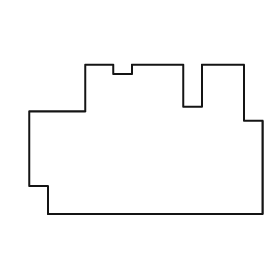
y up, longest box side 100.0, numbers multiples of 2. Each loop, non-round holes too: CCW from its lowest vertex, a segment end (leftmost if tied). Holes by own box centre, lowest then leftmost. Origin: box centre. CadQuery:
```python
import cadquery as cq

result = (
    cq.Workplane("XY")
    .moveTo(-42.0, -32.0)
    .lineTo(50.0, -32.0)
    .lineTo(50.0, 8.0)
    .lineTo(42.0, 8.0)
    .lineTo(42.0, 32.0)
    .lineTo(24.0, 32.0)
    .lineTo(24.0, 14.0)
    .lineTo(16.0, 14.0)
    .lineTo(16.0, 32.0)
    .lineTo(-6.0, 32.0)
    .lineTo(-6.0, 28.0)
    .lineTo(-14.0, 28.0)
    .lineTo(-14.0, 32.0)
    .lineTo(-26.0, 32.0)
    .lineTo(-26.0, 12.0)
    .lineTo(-50.0, 12.0)
    .lineTo(-50.0, -20.0)
    .lineTo(-42.0, -20.0)
    .close()
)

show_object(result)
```